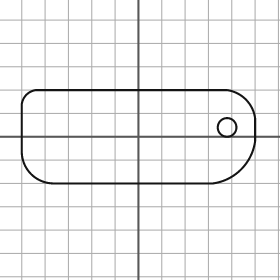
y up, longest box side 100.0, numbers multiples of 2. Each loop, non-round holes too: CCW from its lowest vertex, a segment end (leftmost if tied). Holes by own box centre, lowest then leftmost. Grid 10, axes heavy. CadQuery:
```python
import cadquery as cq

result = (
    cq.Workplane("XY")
    .moveTo(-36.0, -20.0)
    .lineTo(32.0, -20.0)
    .threePointArc((44.0, -14.0), (50.0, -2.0))
    .lineTo(50.0, 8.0)
    .threePointArc((46.0, 16.0), (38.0, 20.0))
    .lineTo(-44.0, 20.0)
    .threePointArc((-48.0, 18.0), (-50.0, 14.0))
    .lineTo(-50.0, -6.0)
    .threePointArc((-46.0, -16.0), (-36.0, -20.0))
    .close()
    .moveTo(38.0, 4.0)
    .circle(4.0)
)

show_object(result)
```